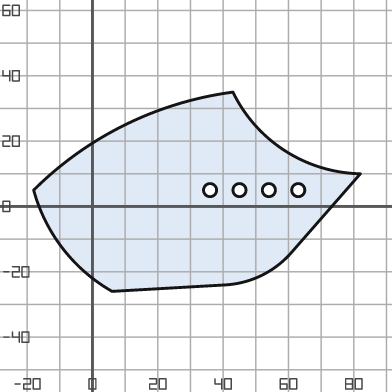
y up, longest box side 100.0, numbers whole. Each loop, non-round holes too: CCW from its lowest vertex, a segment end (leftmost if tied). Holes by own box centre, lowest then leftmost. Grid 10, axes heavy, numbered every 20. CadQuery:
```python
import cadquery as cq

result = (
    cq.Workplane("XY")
    .moveTo(6.0, -26.0)
    .lineTo(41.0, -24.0)
    .threePointArc((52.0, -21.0), (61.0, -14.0))
    .lineTo(82.0, 10.0)
    .threePointArc((59.0, 17.0), (43.0, 35.0))
    .threePointArc((10.0, 25.0), (-18.0, 5.0))
    .threePointArc((-9.0, -13.0), (6.0, -26.0))
    .close()
    .moveTo(36.0, 5.0)
    .circle(2.0)
    .moveTo(45.0, 5.0)
    .circle(2.0)
    .moveTo(54.0, 5.0)
    .circle(2.0)
    .moveTo(63.0, 5.0)
    .circle(2.0)
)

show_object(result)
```